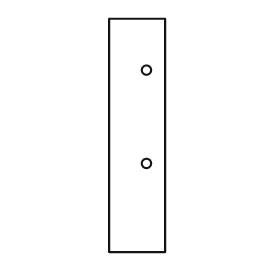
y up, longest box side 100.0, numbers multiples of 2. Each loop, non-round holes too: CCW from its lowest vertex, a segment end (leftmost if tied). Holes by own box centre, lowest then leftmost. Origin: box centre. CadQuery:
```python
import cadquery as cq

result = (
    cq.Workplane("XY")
    .moveTo(-12.0, -50.0)
    .lineTo(12.0, -50.0)
    .lineTo(12.0, 50.0)
    .lineTo(-12.0, 50.0)
    .close()
    .moveTo(4.0, -12.0)
    .circle(2.0)
    .moveTo(4.0, 28.0)
    .circle(2.0)
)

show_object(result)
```